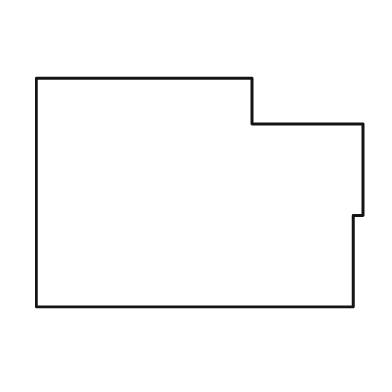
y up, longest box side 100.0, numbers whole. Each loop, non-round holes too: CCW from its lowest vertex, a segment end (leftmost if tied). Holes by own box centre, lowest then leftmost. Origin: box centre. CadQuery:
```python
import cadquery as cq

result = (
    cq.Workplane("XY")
    .moveTo(-50.0, -35.0)
    .lineTo(47.0, -35.0)
    .lineTo(47.0, -7.0)
    .lineTo(50.0, -7.0)
    .lineTo(50.0, 21.0)
    .lineTo(16.0, 21.0)
    .lineTo(16.0, 35.0)
    .lineTo(-50.0, 35.0)
    .close()
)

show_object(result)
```